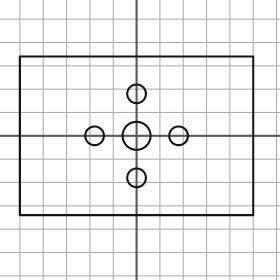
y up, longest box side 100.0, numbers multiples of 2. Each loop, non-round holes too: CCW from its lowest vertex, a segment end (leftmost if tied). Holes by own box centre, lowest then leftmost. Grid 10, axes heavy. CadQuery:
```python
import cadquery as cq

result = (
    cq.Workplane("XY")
    .moveTo(-50.0, -34.0)
    .lineTo(50.0, -34.0)
    .lineTo(50.0, 34.0)
    .lineTo(-50.0, 34.0)
    .close()
    .moveTo(0.0, -18.0)
    .circle(4.0)
    .moveTo(-18.0, 0.0)
    .circle(4.0)
    .moveTo(0.0, 0.0)
    .circle(6.0)
    .moveTo(18.0, 0.0)
    .circle(4.0)
    .moveTo(0.0, 18.0)
    .circle(4.0)
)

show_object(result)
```